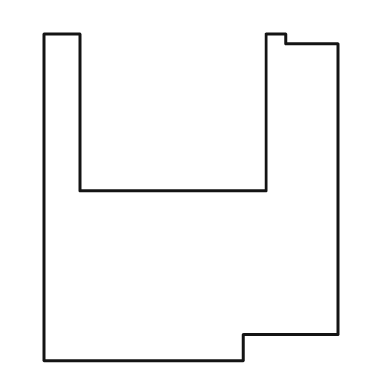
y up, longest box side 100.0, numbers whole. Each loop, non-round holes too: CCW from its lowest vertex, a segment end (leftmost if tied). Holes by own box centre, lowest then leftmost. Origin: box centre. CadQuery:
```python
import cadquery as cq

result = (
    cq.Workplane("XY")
    .moveTo(-45.0, -50.0)
    .lineTo(16.0, -50.0)
    .lineTo(16.0, -42.0)
    .lineTo(45.0, -42.0)
    .lineTo(45.0, 47.0)
    .lineTo(29.0, 47.0)
    .lineTo(29.0, 50.0)
    .lineTo(23.0, 50.0)
    .lineTo(23.0, 2.0)
    .lineTo(-34.0, 2.0)
    .lineTo(-34.0, 50.0)
    .lineTo(-45.0, 50.0)
    .close()
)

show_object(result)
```